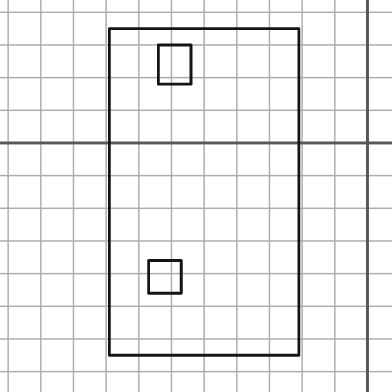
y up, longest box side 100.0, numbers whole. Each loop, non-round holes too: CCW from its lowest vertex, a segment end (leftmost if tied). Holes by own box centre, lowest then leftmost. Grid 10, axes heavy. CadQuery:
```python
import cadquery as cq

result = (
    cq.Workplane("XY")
    .moveTo(-79.0, -65.0)
    .lineTo(-21.0, -65.0)
    .lineTo(-21.0, 35.0)
    .lineTo(-79.0, 35.0)
    .close()
    .moveTo(-67.0, -46.0)
    .lineTo(-57.0, -46.0)
    .lineTo(-57.0, -36.0)
    .lineTo(-67.0, -36.0)
    .close()
    .moveTo(-64.0, 18.0)
    .lineTo(-54.0, 18.0)
    .lineTo(-54.0, 30.0)
    .lineTo(-64.0, 30.0)
    .close()
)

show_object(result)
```